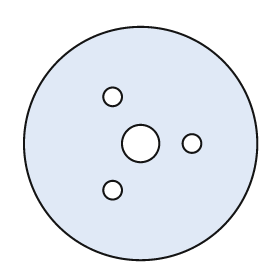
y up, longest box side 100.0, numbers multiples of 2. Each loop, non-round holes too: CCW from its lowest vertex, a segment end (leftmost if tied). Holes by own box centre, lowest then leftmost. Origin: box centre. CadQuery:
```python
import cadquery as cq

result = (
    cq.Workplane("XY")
    .moveTo(0.0, 0.0)
    .circle(50.0)
    .moveTo(-12.0, -20.0)
    .circle(4.0)
    .moveTo(0.0, 0.0)
    .circle(8.0)
    .moveTo(22.0, 0.0)
    .circle(4.0)
    .moveTo(-12.0, 20.0)
    .circle(4.0)
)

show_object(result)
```